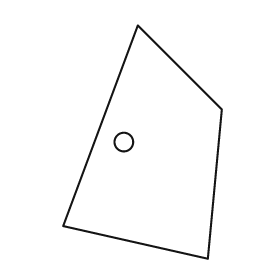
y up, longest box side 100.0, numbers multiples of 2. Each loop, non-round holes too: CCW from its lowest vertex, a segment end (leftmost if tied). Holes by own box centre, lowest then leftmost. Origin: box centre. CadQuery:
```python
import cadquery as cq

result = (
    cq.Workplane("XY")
    .moveTo(28.0, -50.0)
    .lineTo(34.0, 14.0)
    .lineTo(-2.0, 50.0)
    .lineTo(-34.0, -36.0)
    .close()
    .moveTo(-8.0, 0.0)
    .circle(4.0)
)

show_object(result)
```